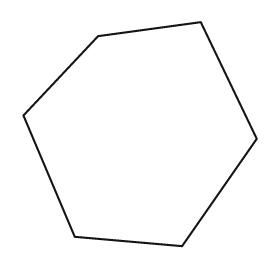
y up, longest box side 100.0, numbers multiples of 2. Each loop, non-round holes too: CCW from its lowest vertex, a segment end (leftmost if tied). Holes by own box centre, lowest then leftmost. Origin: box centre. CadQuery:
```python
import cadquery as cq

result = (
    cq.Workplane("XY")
    .moveTo(18.0, -48.0)
    .lineTo(50.0, -2.0)
    .lineTo(26.0, 48.0)
    .lineTo(-18.0, 42.0)
    .lineTo(-50.0, 8.0)
    .lineTo(-28.0, -44.0)
    .close()
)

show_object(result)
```